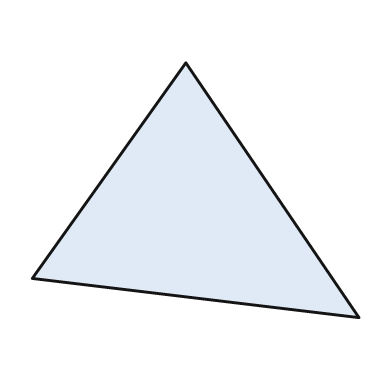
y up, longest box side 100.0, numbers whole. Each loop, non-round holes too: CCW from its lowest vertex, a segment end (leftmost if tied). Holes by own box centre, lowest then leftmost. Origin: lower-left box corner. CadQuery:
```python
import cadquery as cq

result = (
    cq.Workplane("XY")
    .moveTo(100.0, 0.0)
    .lineTo(47.0, 78.0)
    .lineTo(0.0, 12.0)
    .close()
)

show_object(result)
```